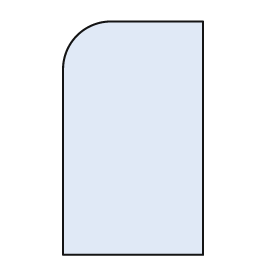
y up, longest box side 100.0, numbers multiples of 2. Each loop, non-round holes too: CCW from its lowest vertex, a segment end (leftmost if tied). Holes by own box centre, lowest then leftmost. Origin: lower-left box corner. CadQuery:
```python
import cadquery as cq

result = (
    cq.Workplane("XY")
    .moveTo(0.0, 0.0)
    .lineTo(60.0, 0.0)
    .lineTo(60.0, 100.0)
    .lineTo(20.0, 100.0)
    .threePointArc((6.0, 94.0), (0.0, 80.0))
    .close()
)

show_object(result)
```